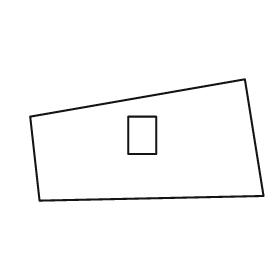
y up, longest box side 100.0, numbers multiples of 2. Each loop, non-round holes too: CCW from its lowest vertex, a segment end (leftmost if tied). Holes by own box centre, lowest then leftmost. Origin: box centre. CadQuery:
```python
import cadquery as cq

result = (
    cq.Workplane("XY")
    .moveTo(-46.0, -26.0)
    .lineTo(50.0, -24.0)
    .lineTo(42.0, 26.0)
    .lineTo(-50.0, 10.0)
    .close()
    .moveTo(-8.0, -6.0)
    .lineTo(4.0, -6.0)
    .lineTo(4.0, 10.0)
    .lineTo(-8.0, 10.0)
    .close()
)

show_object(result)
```